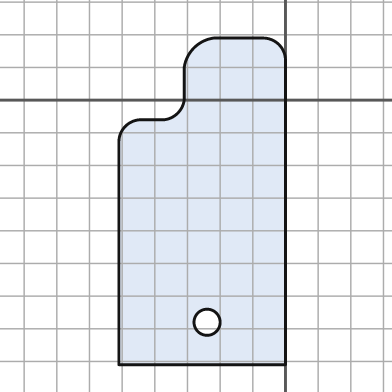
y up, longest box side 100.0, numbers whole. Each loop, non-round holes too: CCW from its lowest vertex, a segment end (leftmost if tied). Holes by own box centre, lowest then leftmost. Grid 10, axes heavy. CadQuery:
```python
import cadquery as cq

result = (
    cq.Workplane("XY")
    .moveTo(-51.0, -81.0)
    .lineTo(0.0, -81.0)
    .lineTo(0.0, 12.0)
    .threePointArc((-2.0, 17.0), (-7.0, 19.0))
    .lineTo(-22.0, 19.0)
    .threePointArc((-28.0, 16.0), (-31.0, 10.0))
    .lineTo(-31.0, 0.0)
    .threePointArc((-33.0, -4.0), (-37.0, -6.0))
    .lineTo(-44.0, -6.0)
    .threePointArc((-49.0, -8.0), (-51.0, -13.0))
    .close()
    .moveTo(-24.0, -68.0)
    .circle(4.0)
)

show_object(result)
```